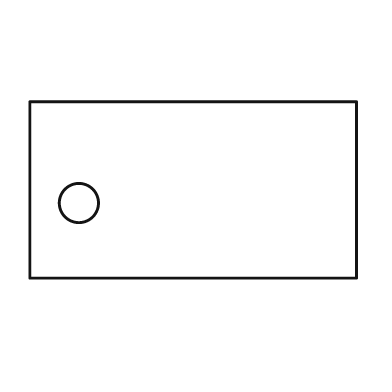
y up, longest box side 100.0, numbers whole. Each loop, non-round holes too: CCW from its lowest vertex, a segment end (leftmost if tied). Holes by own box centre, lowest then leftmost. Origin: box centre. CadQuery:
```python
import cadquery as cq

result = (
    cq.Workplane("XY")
    .moveTo(-50.0, -27.0)
    .lineTo(50.0, -27.0)
    .lineTo(50.0, 27.0)
    .lineTo(-50.0, 27.0)
    .close()
    .moveTo(-35.0, -4.0)
    .circle(6.0)
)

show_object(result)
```